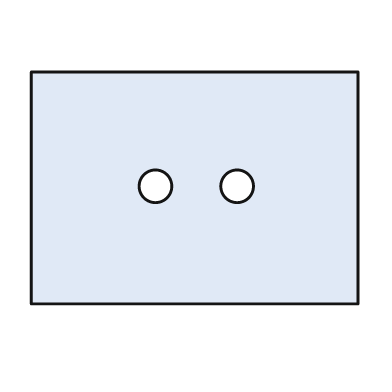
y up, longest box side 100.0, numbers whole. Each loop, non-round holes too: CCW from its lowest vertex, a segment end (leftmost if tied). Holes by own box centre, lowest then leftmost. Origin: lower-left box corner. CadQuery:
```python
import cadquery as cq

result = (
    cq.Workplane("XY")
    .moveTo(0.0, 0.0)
    .lineTo(100.0, 0.0)
    .lineTo(100.0, 71.0)
    .lineTo(0.0, 71.0)
    .close()
    .moveTo(38.0, 36.0)
    .circle(5.0)
    .moveTo(63.0, 36.0)
    .circle(5.0)
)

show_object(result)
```